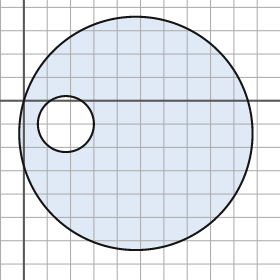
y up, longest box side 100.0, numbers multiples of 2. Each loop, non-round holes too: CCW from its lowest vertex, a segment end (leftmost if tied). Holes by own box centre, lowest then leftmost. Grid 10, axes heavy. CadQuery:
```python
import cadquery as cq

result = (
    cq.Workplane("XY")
    .moveTo(48.0, -14.0)
    .circle(50.0)
    .moveTo(18.0, -10.0)
    .circle(12.0)
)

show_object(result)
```